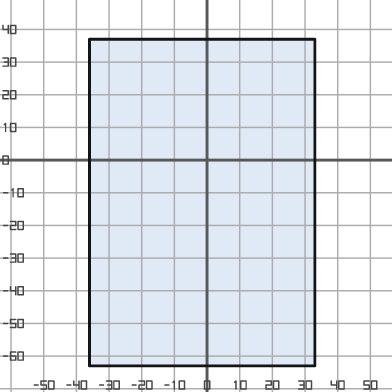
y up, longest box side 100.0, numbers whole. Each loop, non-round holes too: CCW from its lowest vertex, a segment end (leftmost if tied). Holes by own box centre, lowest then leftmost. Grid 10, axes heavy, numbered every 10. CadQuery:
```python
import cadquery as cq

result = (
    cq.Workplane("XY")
    .moveTo(-36.0, -63.0)
    .lineTo(33.0, -63.0)
    .lineTo(33.0, 37.0)
    .lineTo(-36.0, 37.0)
    .close()
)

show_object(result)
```